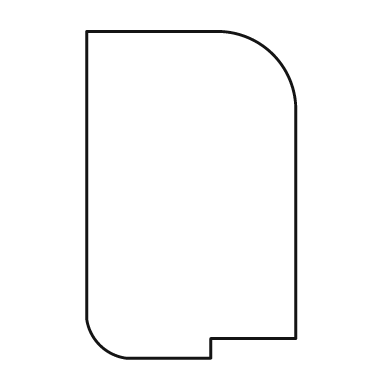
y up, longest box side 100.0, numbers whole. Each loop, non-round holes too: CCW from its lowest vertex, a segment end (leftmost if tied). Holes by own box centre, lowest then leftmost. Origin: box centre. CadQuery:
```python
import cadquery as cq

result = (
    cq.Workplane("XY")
    .moveTo(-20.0, -50.0)
    .lineTo(6.0, -50.0)
    .lineTo(6.0, -44.0)
    .lineTo(32.0, -44.0)
    .lineTo(32.0, 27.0)
    .threePointArc((25.0, 43.0), (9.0, 50.0))
    .lineTo(-32.0, 50.0)
    .lineTo(-32.0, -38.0)
    .threePointArc((-28.0, -46.0), (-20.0, -50.0))
    .close()
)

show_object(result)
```